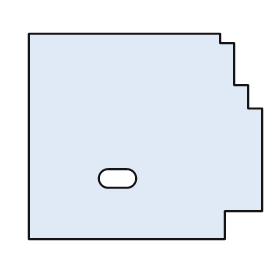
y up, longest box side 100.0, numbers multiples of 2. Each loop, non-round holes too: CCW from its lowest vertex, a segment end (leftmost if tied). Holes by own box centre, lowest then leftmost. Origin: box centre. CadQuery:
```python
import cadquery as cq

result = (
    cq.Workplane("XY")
    .moveTo(-50.0, -44.0)
    .lineTo(34.0, -44.0)
    .lineTo(34.0, -32.0)
    .lineTo(50.0, -32.0)
    .lineTo(50.0, 12.0)
    .lineTo(44.0, 12.0)
    .lineTo(44.0, 22.0)
    .lineTo(38.0, 22.0)
    .lineTo(38.0, 40.0)
    .lineTo(32.0, 40.0)
    .lineTo(32.0, 44.0)
    .lineTo(-50.0, 44.0)
    .close()
    .moveTo(-16.0, -22.0)
    .lineTo(-8.0, -22.0)
    .threePointArc((-4.0, -18.0), (-8.0, -14.0))
    .lineTo(-16.0, -14.0)
    .threePointArc((-20.0, -18.0), (-16.0, -22.0))
    .close()
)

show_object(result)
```